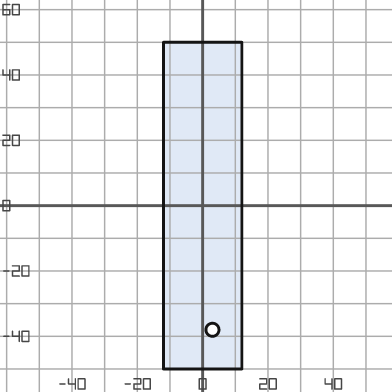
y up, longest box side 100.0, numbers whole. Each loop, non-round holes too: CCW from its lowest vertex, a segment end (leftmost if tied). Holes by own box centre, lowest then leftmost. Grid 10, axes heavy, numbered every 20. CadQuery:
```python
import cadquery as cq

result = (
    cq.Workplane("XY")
    .moveTo(-12.0, -50.0)
    .lineTo(12.0, -50.0)
    .lineTo(12.0, 50.0)
    .lineTo(-12.0, 50.0)
    .close()
    .moveTo(3.0, -38.0)
    .circle(2.0)
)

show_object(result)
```